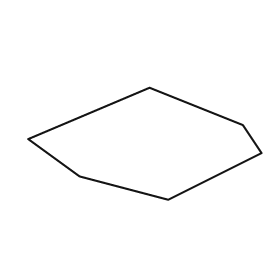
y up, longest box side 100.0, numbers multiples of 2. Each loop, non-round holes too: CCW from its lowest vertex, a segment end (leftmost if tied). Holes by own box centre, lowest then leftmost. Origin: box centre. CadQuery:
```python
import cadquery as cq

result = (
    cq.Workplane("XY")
    .moveTo(10.0, -24.0)
    .lineTo(50.0, -4.0)
    .lineTo(42.0, 8.0)
    .lineTo(2.0, 24.0)
    .lineTo(-50.0, 2.0)
    .lineTo(-28.0, -14.0)
    .close()
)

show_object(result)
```